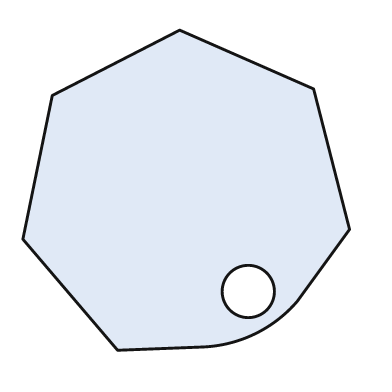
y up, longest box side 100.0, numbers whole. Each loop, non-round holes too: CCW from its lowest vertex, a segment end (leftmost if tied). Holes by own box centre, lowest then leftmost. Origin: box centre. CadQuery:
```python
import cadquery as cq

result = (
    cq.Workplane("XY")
    .moveTo(-21.0, -49.0)
    .lineTo(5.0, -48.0)
    .threePointArc((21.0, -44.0), (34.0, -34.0))
    .lineTo(50.0, -12.0)
    .lineTo(39.0, 31.0)
    .lineTo(-2.0, 49.0)
    .lineTo(-41.0, 29.0)
    .lineTo(-50.0, -15.0)
    .close()
    .moveTo(19.0, -31.0)
    .circle(8.0)
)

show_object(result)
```